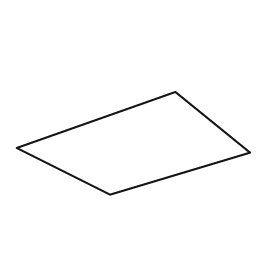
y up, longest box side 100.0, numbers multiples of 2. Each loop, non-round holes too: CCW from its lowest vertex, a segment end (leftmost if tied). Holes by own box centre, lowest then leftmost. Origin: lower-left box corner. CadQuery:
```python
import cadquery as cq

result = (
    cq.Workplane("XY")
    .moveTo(40.0, 0.0)
    .lineTo(100.0, 18.0)
    .lineTo(68.0, 44.0)
    .lineTo(0.0, 20.0)
    .close()
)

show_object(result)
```